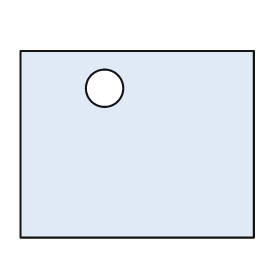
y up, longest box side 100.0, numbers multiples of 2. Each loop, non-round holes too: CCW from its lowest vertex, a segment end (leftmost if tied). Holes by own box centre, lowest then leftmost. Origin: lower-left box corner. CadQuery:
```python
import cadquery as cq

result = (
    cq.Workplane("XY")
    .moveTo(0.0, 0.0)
    .lineTo(100.0, 0.0)
    .lineTo(100.0, 80.0)
    .lineTo(0.0, 80.0)
    .close()
    .moveTo(36.0, 64.0)
    .circle(8.0)
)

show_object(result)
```